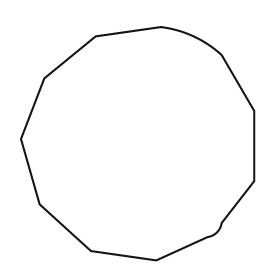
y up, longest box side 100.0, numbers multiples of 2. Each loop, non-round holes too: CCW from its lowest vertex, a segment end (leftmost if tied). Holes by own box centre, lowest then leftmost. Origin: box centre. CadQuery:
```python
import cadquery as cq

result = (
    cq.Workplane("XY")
    .moveTo(8.0, -50.0)
    .lineTo(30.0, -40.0)
    .threePointArc((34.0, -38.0), (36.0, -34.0))
    .lineTo(50.0, -16.0)
    .lineTo(50.0, 14.0)
    .lineTo(36.0, 38.0)
    .threePointArc((24.0, 46.0), (10.0, 50.0))
    .lineTo(-18.0, 46.0)
    .lineTo(-40.0, 28.0)
    .lineTo(-50.0, 2.0)
    .lineTo(-42.0, -26.0)
    .lineTo(-20.0, -46.0)
    .close()
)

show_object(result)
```